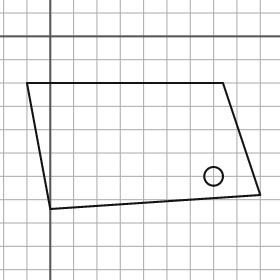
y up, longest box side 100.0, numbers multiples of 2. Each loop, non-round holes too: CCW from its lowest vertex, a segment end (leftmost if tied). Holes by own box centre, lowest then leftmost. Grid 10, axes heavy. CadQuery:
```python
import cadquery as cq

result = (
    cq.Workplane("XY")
    .moveTo(0.0, -74.0)
    .lineTo(90.0, -68.0)
    .lineTo(74.0, -20.0)
    .lineTo(-10.0, -20.0)
    .close()
    .moveTo(70.0, -60.0)
    .circle(4.0)
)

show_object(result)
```